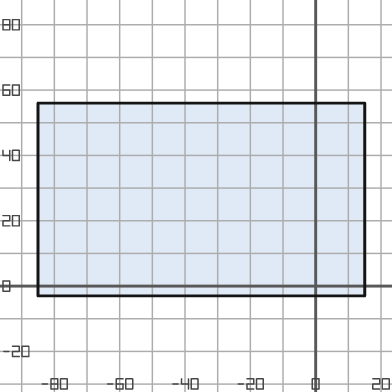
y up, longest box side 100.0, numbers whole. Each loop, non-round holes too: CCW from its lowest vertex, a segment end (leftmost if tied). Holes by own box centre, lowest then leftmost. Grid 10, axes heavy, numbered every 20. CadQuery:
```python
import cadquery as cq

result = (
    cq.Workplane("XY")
    .moveTo(-85.0, -3.0)
    .lineTo(15.0, -3.0)
    .lineTo(15.0, 56.0)
    .lineTo(-85.0, 56.0)
    .close()
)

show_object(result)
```